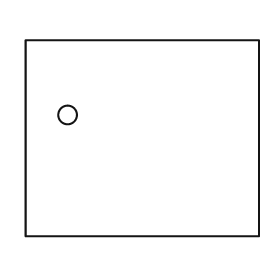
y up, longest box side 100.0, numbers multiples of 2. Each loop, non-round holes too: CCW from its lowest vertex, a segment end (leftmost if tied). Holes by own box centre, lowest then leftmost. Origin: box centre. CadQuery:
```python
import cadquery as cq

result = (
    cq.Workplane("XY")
    .moveTo(-50.0, -42.0)
    .lineTo(50.0, -42.0)
    .lineTo(50.0, 42.0)
    .lineTo(-50.0, 42.0)
    .close()
    .moveTo(-32.0, 10.0)
    .circle(4.0)
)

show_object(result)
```